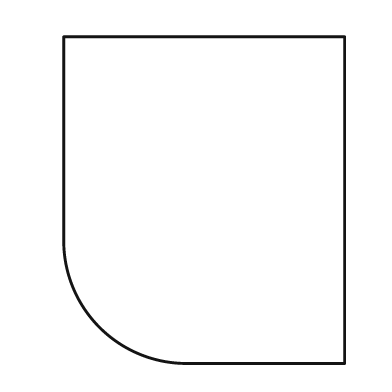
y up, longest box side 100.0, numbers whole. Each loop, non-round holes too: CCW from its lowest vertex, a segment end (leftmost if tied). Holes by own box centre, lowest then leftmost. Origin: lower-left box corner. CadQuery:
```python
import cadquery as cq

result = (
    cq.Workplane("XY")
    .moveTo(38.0, 0.0)
    .lineTo(86.0, 0.0)
    .lineTo(86.0, 100.0)
    .lineTo(0.0, 100.0)
    .lineTo(0.0, 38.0)
    .threePointArc((11.0, 11.0), (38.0, 0.0))
    .close()
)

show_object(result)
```